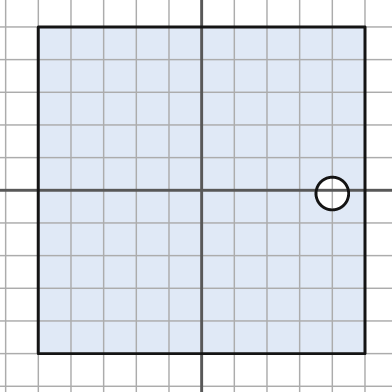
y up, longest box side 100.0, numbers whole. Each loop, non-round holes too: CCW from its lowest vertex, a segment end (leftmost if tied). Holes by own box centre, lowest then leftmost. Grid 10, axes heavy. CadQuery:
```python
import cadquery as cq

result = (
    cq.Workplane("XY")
    .moveTo(-50.0, -50.0)
    .lineTo(50.0, -50.0)
    .lineTo(50.0, 50.0)
    .lineTo(-50.0, 50.0)
    .close()
    .moveTo(40.0, -1.0)
    .circle(5.0)
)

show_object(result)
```